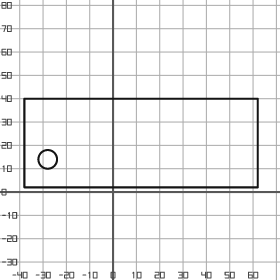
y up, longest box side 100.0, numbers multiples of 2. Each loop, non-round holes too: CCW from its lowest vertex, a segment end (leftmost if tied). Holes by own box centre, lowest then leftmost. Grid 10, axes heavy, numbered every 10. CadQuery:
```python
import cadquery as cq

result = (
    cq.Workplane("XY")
    .moveTo(-38.0, 2.0)
    .lineTo(62.0, 2.0)
    .lineTo(62.0, 40.0)
    .lineTo(-38.0, 40.0)
    .close()
    .moveTo(-28.0, 14.0)
    .circle(4.0)
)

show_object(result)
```